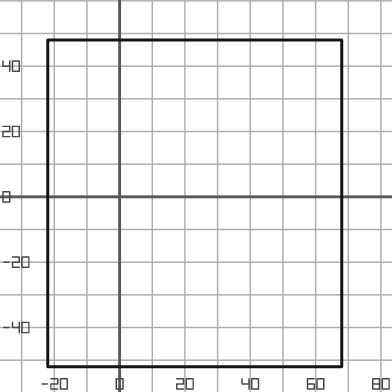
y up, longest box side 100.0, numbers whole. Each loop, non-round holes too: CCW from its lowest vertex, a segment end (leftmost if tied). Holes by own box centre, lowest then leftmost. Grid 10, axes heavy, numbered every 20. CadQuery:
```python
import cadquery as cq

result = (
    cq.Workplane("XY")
    .moveTo(-22.0, -52.0)
    .lineTo(68.0, -52.0)
    .lineTo(68.0, 48.0)
    .lineTo(-22.0, 48.0)
    .close()
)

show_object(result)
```